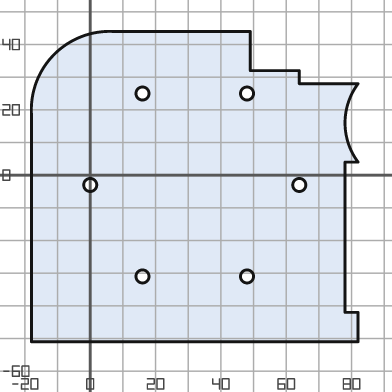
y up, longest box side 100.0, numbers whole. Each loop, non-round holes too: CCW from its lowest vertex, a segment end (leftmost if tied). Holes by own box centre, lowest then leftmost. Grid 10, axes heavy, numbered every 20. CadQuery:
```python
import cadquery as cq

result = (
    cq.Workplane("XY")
    .moveTo(-18.0, -51.0)
    .lineTo(82.0, -51.0)
    .lineTo(82.0, -42.0)
    .lineTo(78.0, -42.0)
    .lineTo(78.0, 4.0)
    .lineTo(82.0, 4.0)
    .threePointArc((78.0, 16.0), (82.0, 28.0))
    .lineTo(64.0, 28.0)
    .lineTo(64.0, 32.0)
    .lineTo(49.0, 32.0)
    .lineTo(49.0, 44.0)
    .lineTo(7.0, 44.0)
    .threePointArc((-11.0, 37.0), (-18.0, 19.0))
    .close()
    .moveTo(16.0, -31.0)
    .circle(2.0)
    .moveTo(48.0, -31.0)
    .circle(2.0)
    .moveTo(0.0, -3.0)
    .circle(2.0)
    .moveTo(64.0, -3.0)
    .circle(2.0)
    .moveTo(16.0, 25.0)
    .circle(2.0)
    .moveTo(48.0, 25.0)
    .circle(2.0)
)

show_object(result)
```